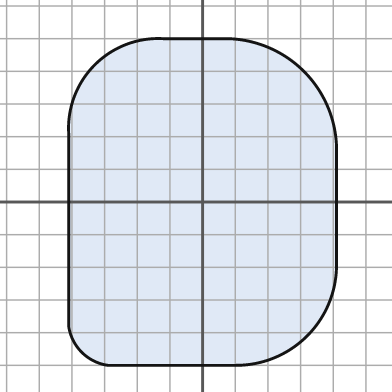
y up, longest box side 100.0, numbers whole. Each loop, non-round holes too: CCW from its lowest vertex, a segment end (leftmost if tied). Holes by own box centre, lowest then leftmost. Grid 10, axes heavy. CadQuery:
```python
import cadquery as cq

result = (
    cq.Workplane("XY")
    .moveTo(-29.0, -50.0)
    .lineTo(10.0, -50.0)
    .threePointArc((32.0, -41.0), (41.0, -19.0))
    .lineTo(41.0, 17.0)
    .threePointArc((31.0, 40.0), (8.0, 50.0))
    .lineTo(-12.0, 50.0)
    .threePointArc((-33.0, 42.0), (-41.0, 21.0))
    .lineTo(-41.0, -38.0)
    .threePointArc((-37.0, -46.0), (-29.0, -50.0))
    .close()
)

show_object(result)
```